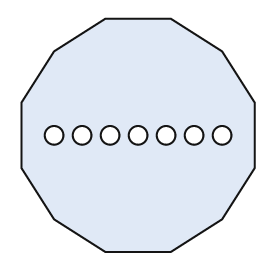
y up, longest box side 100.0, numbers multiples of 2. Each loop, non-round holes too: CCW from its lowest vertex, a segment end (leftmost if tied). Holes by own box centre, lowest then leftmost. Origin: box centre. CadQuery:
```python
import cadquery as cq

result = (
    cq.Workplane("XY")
    .moveTo(-14.0, -50.0)
    .lineTo(14.0, -50.0)
    .lineTo(36.0, -36.0)
    .lineTo(50.0, -14.0)
    .lineTo(50.0, 14.0)
    .lineTo(36.0, 36.0)
    .lineTo(14.0, 50.0)
    .lineTo(-14.0, 50.0)
    .lineTo(-36.0, 36.0)
    .lineTo(-50.0, 14.0)
    .lineTo(-50.0, -14.0)
    .lineTo(-36.0, -36.0)
    .close()
    .moveTo(-36.0, 0.0)
    .circle(4.0)
    .moveTo(-24.0, 0.0)
    .circle(4.0)
    .moveTo(-12.0, 0.0)
    .circle(4.0)
    .moveTo(0.0, 0.0)
    .circle(4.0)
    .moveTo(12.0, 0.0)
    .circle(4.0)
    .moveTo(24.0, 0.0)
    .circle(4.0)
    .moveTo(36.0, 0.0)
    .circle(4.0)
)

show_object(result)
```